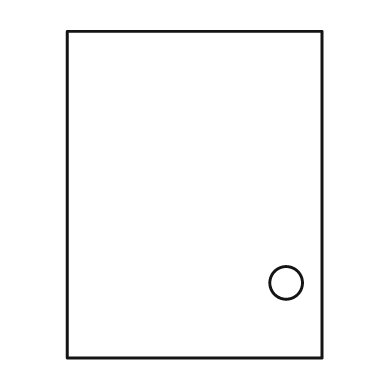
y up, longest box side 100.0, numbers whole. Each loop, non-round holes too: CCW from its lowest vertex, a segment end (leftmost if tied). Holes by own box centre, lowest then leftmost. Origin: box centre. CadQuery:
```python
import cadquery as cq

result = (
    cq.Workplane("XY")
    .moveTo(-39.0, -50.0)
    .lineTo(39.0, -50.0)
    .lineTo(39.0, 50.0)
    .lineTo(-39.0, 50.0)
    .close()
    .moveTo(28.0, -27.0)
    .circle(5.0)
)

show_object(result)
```